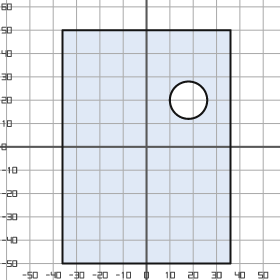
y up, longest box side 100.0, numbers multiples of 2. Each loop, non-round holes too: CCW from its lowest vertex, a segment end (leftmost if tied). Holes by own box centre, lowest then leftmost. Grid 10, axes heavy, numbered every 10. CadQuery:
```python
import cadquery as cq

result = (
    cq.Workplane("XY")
    .moveTo(-36.0, -50.0)
    .lineTo(36.0, -50.0)
    .lineTo(36.0, 50.0)
    .lineTo(-36.0, 50.0)
    .close()
    .moveTo(18.0, 20.0)
    .circle(8.0)
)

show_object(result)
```